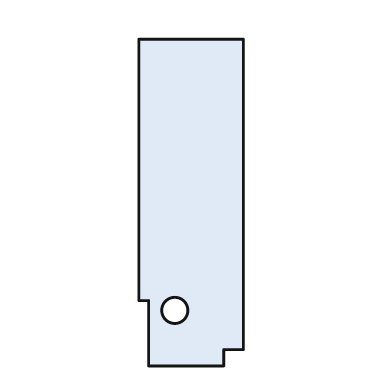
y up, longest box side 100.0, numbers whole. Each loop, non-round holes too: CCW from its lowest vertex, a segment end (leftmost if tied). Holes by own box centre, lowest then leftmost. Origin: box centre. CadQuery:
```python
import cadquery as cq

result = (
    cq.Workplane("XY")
    .moveTo(-13.0, -50.0)
    .lineTo(10.0, -50.0)
    .lineTo(10.0, -45.0)
    .lineTo(16.0, -45.0)
    .lineTo(16.0, 50.0)
    .lineTo(-16.0, 50.0)
    .lineTo(-16.0, -30.0)
    .lineTo(-13.0, -30.0)
    .close()
    .moveTo(-5.0, -33.0)
    .circle(4.0)
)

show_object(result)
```